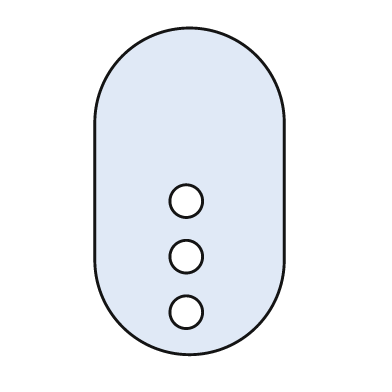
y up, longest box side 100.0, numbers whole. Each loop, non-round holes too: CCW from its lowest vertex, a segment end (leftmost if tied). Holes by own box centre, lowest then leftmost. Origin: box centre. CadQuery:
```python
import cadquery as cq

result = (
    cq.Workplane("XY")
    .moveTo(-29.0, -21.0)
    .threePointArc((0.0, -50.0), (29.0, -21.0))
    .lineTo(29.0, 21.0)
    .threePointArc((0.0, 50.0), (-29.0, 21.0))
    .close()
    .moveTo(-1.0, -37.0)
    .circle(5.0)
    .moveTo(-1.0, -20.0)
    .circle(5.0)
    .moveTo(-1.0, -3.0)
    .circle(5.0)
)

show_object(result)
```